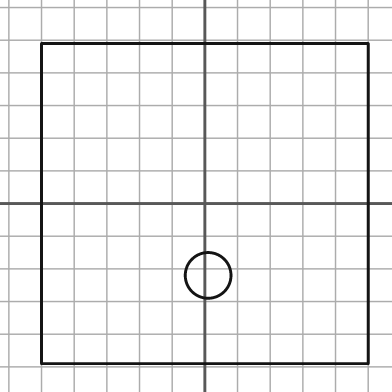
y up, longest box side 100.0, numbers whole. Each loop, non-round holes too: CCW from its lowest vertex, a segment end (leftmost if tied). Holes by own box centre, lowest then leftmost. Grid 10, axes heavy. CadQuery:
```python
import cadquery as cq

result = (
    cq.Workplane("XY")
    .moveTo(-50.0, -49.0)
    .lineTo(50.0, -49.0)
    .lineTo(50.0, 49.0)
    .lineTo(-50.0, 49.0)
    .close()
    .moveTo(1.0, -22.0)
    .circle(7.0)
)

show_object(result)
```